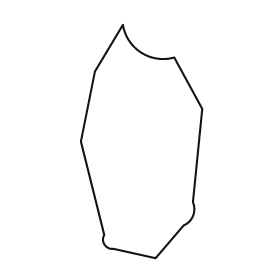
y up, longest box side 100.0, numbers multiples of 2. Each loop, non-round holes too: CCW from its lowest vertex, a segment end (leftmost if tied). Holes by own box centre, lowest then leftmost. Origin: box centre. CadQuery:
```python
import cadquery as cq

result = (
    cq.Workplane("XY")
    .moveTo(6.0, -50.0)
    .lineTo(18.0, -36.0)
    .threePointArc((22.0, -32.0), (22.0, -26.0))
    .lineTo(26.0, 14.0)
    .lineTo(14.0, 36.0)
    .threePointArc((0.0, 38.0), (-8.0, 50.0))
    .lineTo(-20.0, 30.0)
    .lineTo(-26.0, 0.0)
    .lineTo(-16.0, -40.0)
    .threePointArc((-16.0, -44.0), (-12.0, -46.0))
    .close()
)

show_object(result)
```